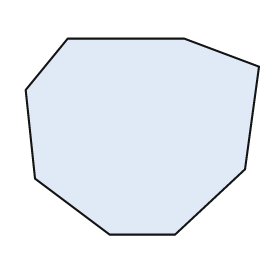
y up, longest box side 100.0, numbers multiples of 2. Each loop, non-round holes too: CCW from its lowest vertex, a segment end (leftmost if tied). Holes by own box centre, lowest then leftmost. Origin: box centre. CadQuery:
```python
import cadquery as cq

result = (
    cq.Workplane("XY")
    .moveTo(-14.0, -42.0)
    .lineTo(14.0, -42.0)
    .lineTo(44.0, -14.0)
    .lineTo(50.0, 30.0)
    .lineTo(18.0, 42.0)
    .lineTo(-32.0, 42.0)
    .lineTo(-50.0, 20.0)
    .lineTo(-46.0, -18.0)
    .close()
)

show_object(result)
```